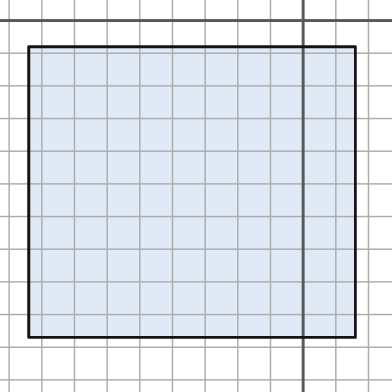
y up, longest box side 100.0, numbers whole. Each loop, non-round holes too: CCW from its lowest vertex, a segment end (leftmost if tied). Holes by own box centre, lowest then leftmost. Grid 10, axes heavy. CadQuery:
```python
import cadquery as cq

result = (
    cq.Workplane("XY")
    .moveTo(-84.0, -97.0)
    .lineTo(16.0, -97.0)
    .lineTo(16.0, -8.0)
    .lineTo(-84.0, -8.0)
    .close()
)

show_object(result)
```